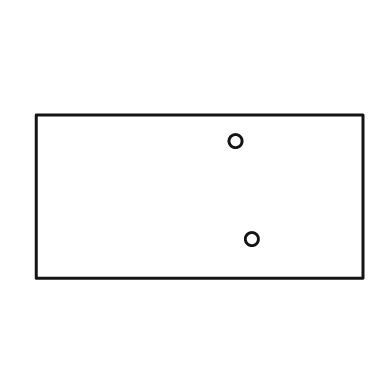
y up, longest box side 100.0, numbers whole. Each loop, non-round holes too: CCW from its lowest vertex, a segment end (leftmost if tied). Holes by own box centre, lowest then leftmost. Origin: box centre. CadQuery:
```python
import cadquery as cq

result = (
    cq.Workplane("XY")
    .moveTo(-50.0, -25.0)
    .lineTo(50.0, -25.0)
    .lineTo(50.0, 25.0)
    .lineTo(-50.0, 25.0)
    .close()
    .moveTo(16.0, -13.0)
    .circle(2.0)
    .moveTo(11.0, 17.0)
    .circle(2.0)
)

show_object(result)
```